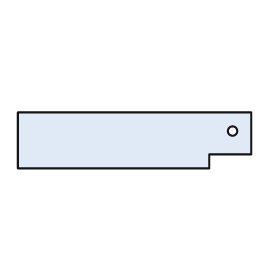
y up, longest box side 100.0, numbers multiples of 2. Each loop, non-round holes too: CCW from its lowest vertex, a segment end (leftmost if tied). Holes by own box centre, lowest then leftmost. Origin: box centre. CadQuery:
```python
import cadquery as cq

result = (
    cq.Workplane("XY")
    .moveTo(-50.0, -12.0)
    .lineTo(32.0, -12.0)
    .lineTo(32.0, -6.0)
    .lineTo(50.0, -6.0)
    .lineTo(50.0, 12.0)
    .lineTo(-50.0, 12.0)
    .close()
    .moveTo(42.0, 4.0)
    .circle(2.0)
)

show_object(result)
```